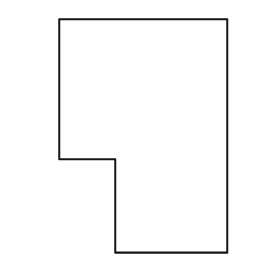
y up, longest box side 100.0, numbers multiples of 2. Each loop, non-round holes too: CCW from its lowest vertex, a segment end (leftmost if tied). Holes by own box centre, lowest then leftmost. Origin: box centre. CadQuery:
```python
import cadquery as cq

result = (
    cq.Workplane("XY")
    .moveTo(-12.0, -50.0)
    .lineTo(36.0, -50.0)
    .lineTo(36.0, 50.0)
    .lineTo(-36.0, 50.0)
    .lineTo(-36.0, -10.0)
    .lineTo(-12.0, -10.0)
    .close()
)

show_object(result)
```